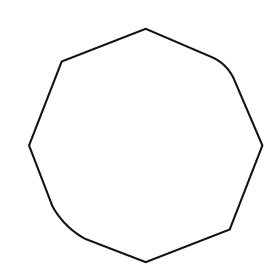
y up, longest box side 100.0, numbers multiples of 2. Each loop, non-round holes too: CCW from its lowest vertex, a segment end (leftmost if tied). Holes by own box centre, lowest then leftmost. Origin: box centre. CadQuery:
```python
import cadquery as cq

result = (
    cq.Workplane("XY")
    .moveTo(0.0, -50.0)
    .lineTo(36.0, -36.0)
    .lineTo(50.0, 0.0)
    .lineTo(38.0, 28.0)
    .threePointArc((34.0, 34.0), (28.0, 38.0))
    .lineTo(0.0, 50.0)
    .lineTo(-36.0, 36.0)
    .lineTo(-50.0, 0.0)
    .lineTo(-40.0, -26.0)
    .threePointArc((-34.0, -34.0), (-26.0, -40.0))
    .close()
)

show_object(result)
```